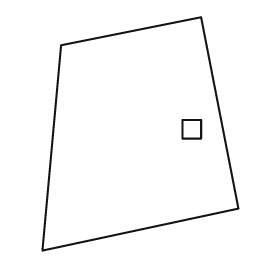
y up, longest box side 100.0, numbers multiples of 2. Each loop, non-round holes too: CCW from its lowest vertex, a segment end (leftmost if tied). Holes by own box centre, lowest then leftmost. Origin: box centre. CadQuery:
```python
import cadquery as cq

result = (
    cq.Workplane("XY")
    .moveTo(-42.0, -50.0)
    .lineTo(42.0, -32.0)
    .lineTo(26.0, 50.0)
    .lineTo(-34.0, 38.0)
    .close()
    .moveTo(18.0, -2.0)
    .lineTo(26.0, -2.0)
    .lineTo(26.0, 6.0)
    .lineTo(18.0, 6.0)
    .close()
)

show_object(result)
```